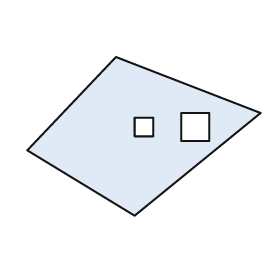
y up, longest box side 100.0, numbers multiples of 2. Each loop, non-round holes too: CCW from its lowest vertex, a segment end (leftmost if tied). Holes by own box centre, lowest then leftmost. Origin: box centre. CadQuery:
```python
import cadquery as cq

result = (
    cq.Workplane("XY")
    .moveTo(-4.0, -34.0)
    .lineTo(50.0, 10.0)
    .lineTo(-12.0, 34.0)
    .lineTo(-50.0, -6.0)
    .close()
    .moveTo(-4.0, 0.0)
    .lineTo(4.0, 0.0)
    .lineTo(4.0, 8.0)
    .lineTo(-4.0, 8.0)
    .close()
    .moveTo(16.0, -2.0)
    .lineTo(28.0, -2.0)
    .lineTo(28.0, 10.0)
    .lineTo(16.0, 10.0)
    .close()
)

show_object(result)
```